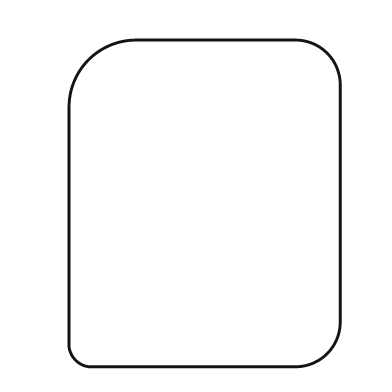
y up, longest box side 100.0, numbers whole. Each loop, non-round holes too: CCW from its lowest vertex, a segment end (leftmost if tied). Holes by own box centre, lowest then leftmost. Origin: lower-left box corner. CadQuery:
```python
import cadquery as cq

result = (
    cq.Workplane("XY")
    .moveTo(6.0, 0.0)
    .lineTo(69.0, 0.0)
    .threePointArc((79.0, 4.0), (83.0, 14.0))
    .lineTo(83.0, 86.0)
    .threePointArc((79.0, 96.0), (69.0, 100.0))
    .lineTo(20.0, 100.0)
    .threePointArc((6.0, 94.0), (0.0, 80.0))
    .lineTo(0.0, 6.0)
    .threePointArc((2.0, 2.0), (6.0, 0.0))
    .close()
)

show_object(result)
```